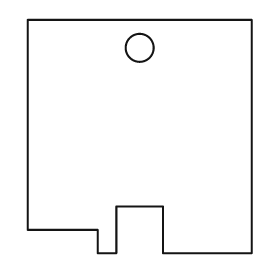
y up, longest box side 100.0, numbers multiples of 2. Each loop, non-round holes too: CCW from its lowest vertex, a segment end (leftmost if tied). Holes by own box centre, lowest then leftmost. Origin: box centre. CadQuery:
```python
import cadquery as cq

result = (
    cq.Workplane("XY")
    .moveTo(-18.0, -50.0)
    .lineTo(-10.0, -50.0)
    .lineTo(-10.0, -30.0)
    .lineTo(10.0, -30.0)
    .lineTo(10.0, -50.0)
    .lineTo(48.0, -50.0)
    .lineTo(48.0, 50.0)
    .lineTo(-48.0, 50.0)
    .lineTo(-48.0, -40.0)
    .lineTo(-18.0, -40.0)
    .close()
    .moveTo(0.0, 38.0)
    .circle(6.0)
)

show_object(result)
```